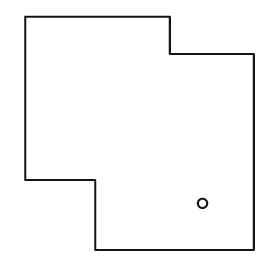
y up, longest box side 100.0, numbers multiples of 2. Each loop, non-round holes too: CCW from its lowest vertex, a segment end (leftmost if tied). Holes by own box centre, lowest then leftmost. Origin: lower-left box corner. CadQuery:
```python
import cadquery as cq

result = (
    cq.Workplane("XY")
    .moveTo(30.0, 0.0)
    .lineTo(98.0, 0.0)
    .lineTo(98.0, 84.0)
    .lineTo(62.0, 84.0)
    .lineTo(62.0, 100.0)
    .lineTo(0.0, 100.0)
    .lineTo(0.0, 30.0)
    .lineTo(30.0, 30.0)
    .close()
    .moveTo(76.0, 20.0)
    .circle(2.0)
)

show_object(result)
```